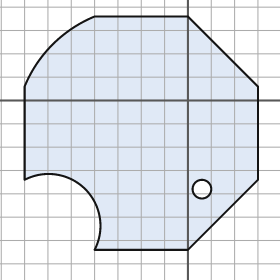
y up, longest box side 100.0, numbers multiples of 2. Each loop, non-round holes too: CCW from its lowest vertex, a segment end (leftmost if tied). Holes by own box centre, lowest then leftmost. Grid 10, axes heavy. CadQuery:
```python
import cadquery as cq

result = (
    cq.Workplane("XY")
    .moveTo(-40.0, -64.0)
    .lineTo(0.0, -64.0)
    .lineTo(30.0, -34.0)
    .lineTo(30.0, 6.0)
    .lineTo(0.0, 36.0)
    .lineTo(-40.0, 36.0)
    .threePointArc((-58.0, 24.0), (-70.0, 6.0))
    .lineTo(-70.0, -34.0)
    .threePointArc((-44.0, -38.0), (-40.0, -64.0))
    .close()
    .moveTo(6.0, -38.0)
    .circle(4.0)
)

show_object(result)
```